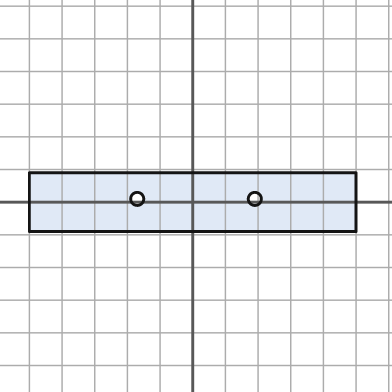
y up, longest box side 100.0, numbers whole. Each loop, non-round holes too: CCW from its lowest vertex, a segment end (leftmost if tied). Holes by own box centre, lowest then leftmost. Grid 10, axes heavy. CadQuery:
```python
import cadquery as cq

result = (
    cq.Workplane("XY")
    .moveTo(-50.0, -9.0)
    .lineTo(50.0, -9.0)
    .lineTo(50.0, 9.0)
    .lineTo(-50.0, 9.0)
    .close()
    .moveTo(-17.0, 1.0)
    .circle(2.0)
    .moveTo(19.0, 1.0)
    .circle(2.0)
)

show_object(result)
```